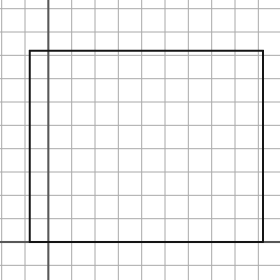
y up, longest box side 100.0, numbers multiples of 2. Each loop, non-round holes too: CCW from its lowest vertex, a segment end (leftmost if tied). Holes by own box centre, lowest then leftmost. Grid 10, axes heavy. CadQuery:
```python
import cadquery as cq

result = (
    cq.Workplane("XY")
    .moveTo(-8.0, 0.0)
    .lineTo(92.0, 0.0)
    .lineTo(92.0, 82.0)
    .lineTo(-8.0, 82.0)
    .close()
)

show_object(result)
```